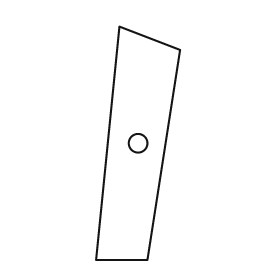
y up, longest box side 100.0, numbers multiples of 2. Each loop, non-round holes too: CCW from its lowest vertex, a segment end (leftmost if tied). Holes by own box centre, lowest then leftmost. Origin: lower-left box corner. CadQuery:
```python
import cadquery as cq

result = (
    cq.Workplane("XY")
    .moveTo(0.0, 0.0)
    .lineTo(22.0, 0.0)
    .lineTo(36.0, 90.0)
    .lineTo(10.0, 100.0)
    .close()
    .moveTo(18.0, 50.0)
    .circle(4.0)
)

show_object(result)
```